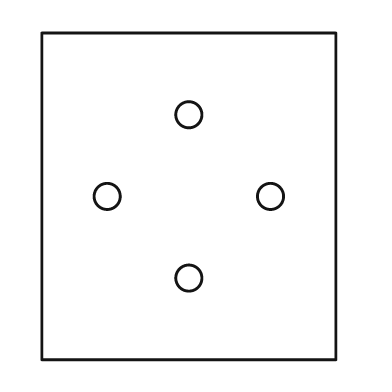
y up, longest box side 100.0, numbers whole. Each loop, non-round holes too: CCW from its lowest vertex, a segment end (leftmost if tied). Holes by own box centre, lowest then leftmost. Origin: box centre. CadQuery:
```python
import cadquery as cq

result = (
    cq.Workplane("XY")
    .moveTo(-45.0, -50.0)
    .lineTo(45.0, -50.0)
    .lineTo(45.0, 50.0)
    .lineTo(-45.0, 50.0)
    .close()
    .moveTo(0.0, -25.0)
    .circle(4.0)
    .moveTo(-25.0, 0.0)
    .circle(4.0)
    .moveTo(25.0, 0.0)
    .circle(4.0)
    .moveTo(0.0, 25.0)
    .circle(4.0)
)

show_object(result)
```